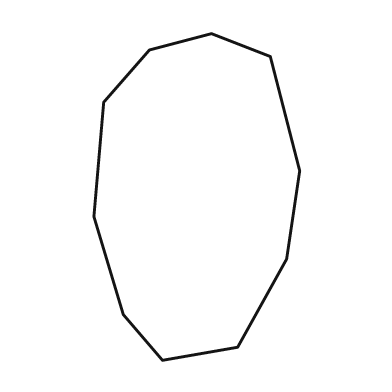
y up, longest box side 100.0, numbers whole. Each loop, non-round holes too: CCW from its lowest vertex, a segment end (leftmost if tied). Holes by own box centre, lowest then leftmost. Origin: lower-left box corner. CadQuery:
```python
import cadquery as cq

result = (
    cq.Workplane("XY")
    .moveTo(21.0, 0.0)
    .lineTo(44.0, 4.0)
    .lineTo(59.0, 31.0)
    .lineTo(63.0, 58.0)
    .lineTo(54.0, 93.0)
    .lineTo(36.0, 100.0)
    .lineTo(17.0, 95.0)
    .lineTo(3.0, 79.0)
    .lineTo(0.0, 44.0)
    .lineTo(9.0, 14.0)
    .close()
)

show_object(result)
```